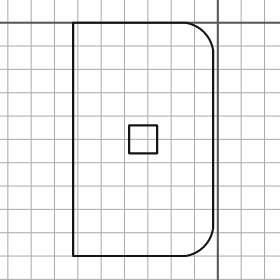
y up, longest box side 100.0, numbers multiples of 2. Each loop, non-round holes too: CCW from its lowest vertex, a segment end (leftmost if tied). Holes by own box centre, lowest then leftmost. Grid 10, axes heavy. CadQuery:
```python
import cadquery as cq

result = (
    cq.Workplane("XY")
    .moveTo(-62.0, -100.0)
    .lineTo(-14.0, -100.0)
    .threePointArc((-6.0, -96.0), (-2.0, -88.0))
    .lineTo(-2.0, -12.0)
    .threePointArc((-6.0, -4.0), (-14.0, 0.0))
    .lineTo(-62.0, 0.0)
    .close()
    .moveTo(-38.0, -56.0)
    .lineTo(-26.0, -56.0)
    .lineTo(-26.0, -44.0)
    .lineTo(-38.0, -44.0)
    .close()
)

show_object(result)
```